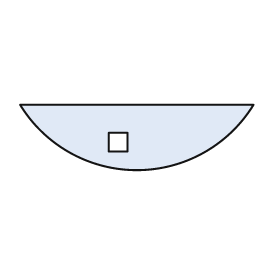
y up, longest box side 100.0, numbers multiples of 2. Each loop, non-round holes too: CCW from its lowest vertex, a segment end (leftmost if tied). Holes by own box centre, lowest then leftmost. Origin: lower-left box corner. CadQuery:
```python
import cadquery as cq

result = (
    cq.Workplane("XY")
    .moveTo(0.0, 28.0)
    .threePointArc((50.0, 0.0), (100.0, 28.0))
    .close()
    .moveTo(38.0, 8.0)
    .lineTo(46.0, 8.0)
    .lineTo(46.0, 16.0)
    .lineTo(38.0, 16.0)
    .close()
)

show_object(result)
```